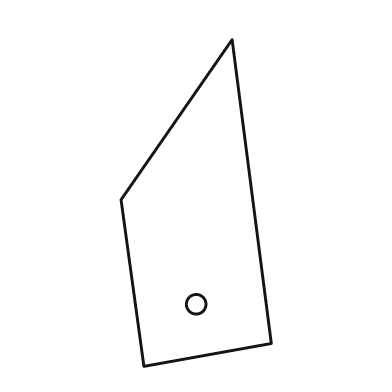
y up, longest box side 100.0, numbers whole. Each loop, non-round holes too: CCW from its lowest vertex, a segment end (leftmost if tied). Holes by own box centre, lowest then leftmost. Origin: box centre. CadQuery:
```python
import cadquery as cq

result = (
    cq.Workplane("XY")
    .moveTo(-16.0, -50.0)
    .lineTo(23.0, -43.0)
    .lineTo(11.0, 50.0)
    .lineTo(-23.0, 1.0)
    .close()
    .moveTo(0.0, -31.0)
    .circle(3.0)
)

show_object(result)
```